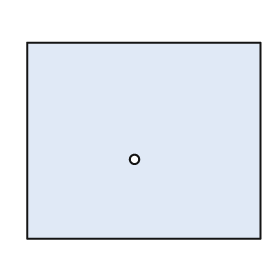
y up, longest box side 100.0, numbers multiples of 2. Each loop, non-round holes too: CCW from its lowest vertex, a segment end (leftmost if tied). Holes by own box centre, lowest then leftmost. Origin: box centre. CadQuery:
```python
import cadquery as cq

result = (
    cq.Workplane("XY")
    .moveTo(-50.0, -42.0)
    .lineTo(50.0, -42.0)
    .lineTo(50.0, 42.0)
    .lineTo(-50.0, 42.0)
    .close()
    .moveTo(-4.0, -8.0)
    .circle(2.0)
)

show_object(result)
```